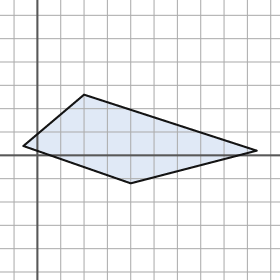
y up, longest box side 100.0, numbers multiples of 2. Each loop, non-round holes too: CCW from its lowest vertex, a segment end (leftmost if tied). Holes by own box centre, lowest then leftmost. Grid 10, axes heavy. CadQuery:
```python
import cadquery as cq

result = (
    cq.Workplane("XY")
    .moveTo(40.0, -12.0)
    .lineTo(94.0, 2.0)
    .lineTo(20.0, 26.0)
    .lineTo(-6.0, 4.0)
    .close()
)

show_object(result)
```